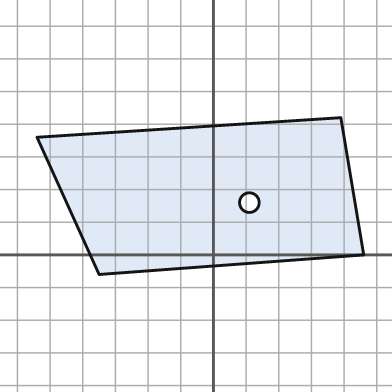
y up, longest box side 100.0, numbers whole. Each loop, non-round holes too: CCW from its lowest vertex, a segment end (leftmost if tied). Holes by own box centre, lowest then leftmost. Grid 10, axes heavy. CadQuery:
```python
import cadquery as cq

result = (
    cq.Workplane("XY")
    .moveTo(-35.0, -6.0)
    .lineTo(46.0, 0.0)
    .lineTo(39.0, 42.0)
    .lineTo(-54.0, 36.0)
    .close()
    .moveTo(11.0, 16.0)
    .circle(3.0)
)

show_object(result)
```